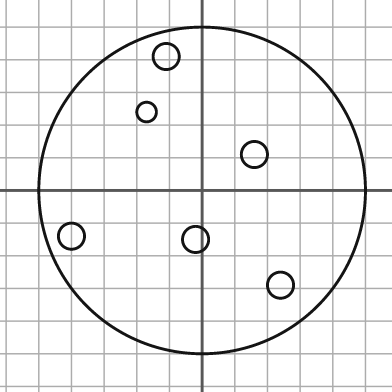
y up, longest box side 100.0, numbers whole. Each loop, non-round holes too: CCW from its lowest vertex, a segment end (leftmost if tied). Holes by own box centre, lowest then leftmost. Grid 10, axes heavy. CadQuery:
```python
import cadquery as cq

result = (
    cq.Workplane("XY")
    .moveTo(0.0, 0.0)
    .circle(50.0)
    .moveTo(24.0, -29.0)
    .circle(4.0)
    .moveTo(-2.0, -15.0)
    .circle(4.0)
    .moveTo(-40.0, -14.0)
    .circle(4.0)
    .moveTo(16.0, 11.0)
    .circle(4.0)
    .moveTo(-17.0, 24.0)
    .circle(3.0)
    .moveTo(-11.0, 41.0)
    .circle(4.0)
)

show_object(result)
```